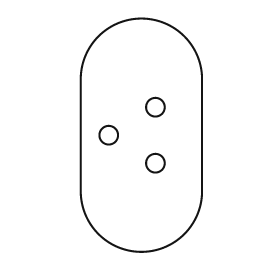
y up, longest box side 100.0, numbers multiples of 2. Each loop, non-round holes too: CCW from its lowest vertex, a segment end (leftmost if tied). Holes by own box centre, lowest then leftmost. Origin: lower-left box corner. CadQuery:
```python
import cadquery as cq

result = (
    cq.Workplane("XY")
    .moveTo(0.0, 26.0)
    .threePointArc((26.0, 0.0), (52.0, 26.0))
    .lineTo(52.0, 74.0)
    .threePointArc((26.0, 100.0), (0.0, 74.0))
    .close()
    .moveTo(32.0, 38.0)
    .circle(4.0)
    .moveTo(12.0, 50.0)
    .circle(4.0)
    .moveTo(32.0, 62.0)
    .circle(4.0)
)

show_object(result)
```